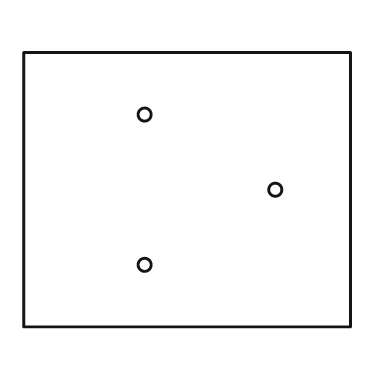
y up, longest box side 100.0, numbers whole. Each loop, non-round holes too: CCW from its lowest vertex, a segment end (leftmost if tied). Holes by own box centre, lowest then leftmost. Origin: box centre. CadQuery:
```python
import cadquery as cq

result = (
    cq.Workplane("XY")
    .moveTo(-50.0, -42.0)
    .lineTo(50.0, -42.0)
    .lineTo(50.0, 42.0)
    .lineTo(-50.0, 42.0)
    .close()
    .moveTo(-13.0, -23.0)
    .circle(2.0)
    .moveTo(27.0, 0.0)
    .circle(2.0)
    .moveTo(-13.0, 23.0)
    .circle(2.0)
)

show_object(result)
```